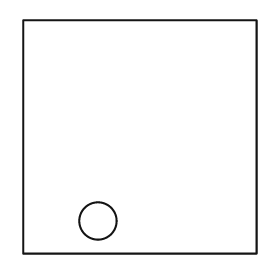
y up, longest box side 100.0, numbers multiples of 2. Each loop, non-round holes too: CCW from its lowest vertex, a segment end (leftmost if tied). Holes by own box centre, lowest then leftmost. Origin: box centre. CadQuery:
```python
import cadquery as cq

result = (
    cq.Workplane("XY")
    .moveTo(-50.0, -50.0)
    .lineTo(50.0, -50.0)
    .lineTo(50.0, 50.0)
    .lineTo(-50.0, 50.0)
    .close()
    .moveTo(-18.0, -36.0)
    .circle(8.0)
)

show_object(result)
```